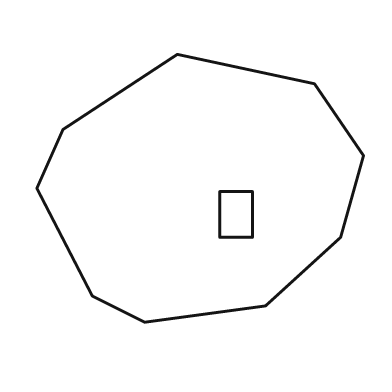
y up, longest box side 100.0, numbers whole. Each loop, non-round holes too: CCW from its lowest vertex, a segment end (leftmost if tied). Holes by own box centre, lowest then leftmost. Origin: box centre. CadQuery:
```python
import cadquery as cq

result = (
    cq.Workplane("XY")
    .moveTo(-17.0, -41.0)
    .lineTo(20.0, -36.0)
    .lineTo(43.0, -15.0)
    .lineTo(50.0, 10.0)
    .lineTo(35.0, 32.0)
    .lineTo(-7.0, 41.0)
    .lineTo(-42.0, 18.0)
    .lineTo(-50.0, 0.0)
    .lineTo(-33.0, -33.0)
    .close()
    .moveTo(6.0, -15.0)
    .lineTo(16.0, -15.0)
    .lineTo(16.0, -1.0)
    .lineTo(6.0, -1.0)
    .close()
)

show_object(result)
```